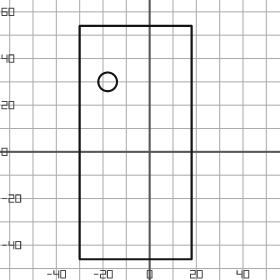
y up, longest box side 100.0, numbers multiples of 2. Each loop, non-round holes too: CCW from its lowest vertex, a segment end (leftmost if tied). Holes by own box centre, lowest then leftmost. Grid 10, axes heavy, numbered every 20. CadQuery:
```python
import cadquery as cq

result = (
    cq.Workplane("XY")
    .moveTo(-30.0, -46.0)
    .lineTo(18.0, -46.0)
    .lineTo(18.0, 54.0)
    .lineTo(-30.0, 54.0)
    .close()
    .moveTo(-18.0, 30.0)
    .circle(4.0)
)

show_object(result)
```